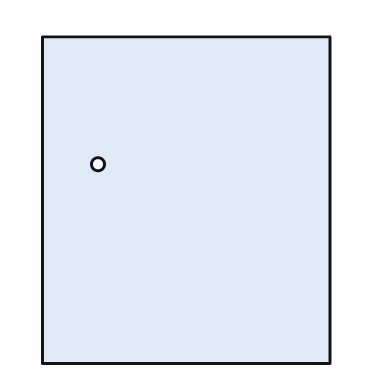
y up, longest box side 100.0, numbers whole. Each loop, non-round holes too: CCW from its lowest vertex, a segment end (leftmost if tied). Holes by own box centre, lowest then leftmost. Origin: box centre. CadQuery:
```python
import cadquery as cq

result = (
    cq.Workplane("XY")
    .moveTo(-44.0, -50.0)
    .lineTo(44.0, -50.0)
    .lineTo(44.0, 50.0)
    .lineTo(-44.0, 50.0)
    .close()
    .moveTo(-27.0, 11.0)
    .circle(2.0)
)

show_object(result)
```